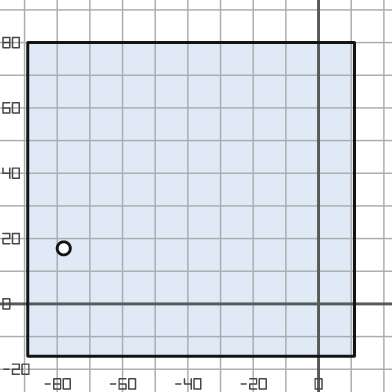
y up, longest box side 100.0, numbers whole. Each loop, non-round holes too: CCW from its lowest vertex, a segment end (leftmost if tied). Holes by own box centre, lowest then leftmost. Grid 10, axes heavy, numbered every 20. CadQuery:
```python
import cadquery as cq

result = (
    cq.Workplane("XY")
    .moveTo(-89.0, -16.0)
    .lineTo(11.0, -16.0)
    .lineTo(11.0, 80.0)
    .lineTo(-89.0, 80.0)
    .close()
    .moveTo(-78.0, 17.0)
    .circle(2.0)
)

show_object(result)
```